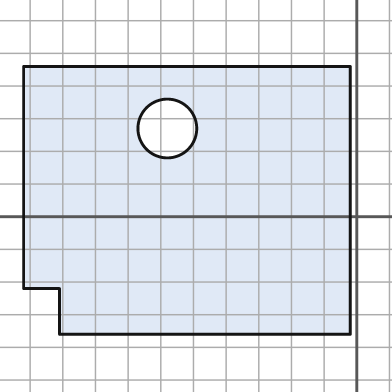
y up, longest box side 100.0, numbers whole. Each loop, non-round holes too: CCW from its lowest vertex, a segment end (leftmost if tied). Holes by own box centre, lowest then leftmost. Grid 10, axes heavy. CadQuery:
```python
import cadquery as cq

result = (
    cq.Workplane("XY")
    .moveTo(-91.0, -36.0)
    .lineTo(-2.0, -36.0)
    .lineTo(-2.0, 46.0)
    .lineTo(-102.0, 46.0)
    .lineTo(-102.0, -22.0)
    .lineTo(-91.0, -22.0)
    .close()
    .moveTo(-58.0, 27.0)
    .circle(9.0)
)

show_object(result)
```